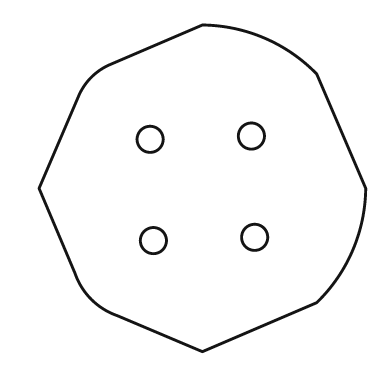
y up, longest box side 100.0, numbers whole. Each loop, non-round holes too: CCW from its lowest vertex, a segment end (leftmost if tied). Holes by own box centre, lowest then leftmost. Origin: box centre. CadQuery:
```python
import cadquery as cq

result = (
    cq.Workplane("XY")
    .moveTo(0.0, -50.0)
    .lineTo(35.0, -35.0)
    .threePointArc((46.0, -19.0), (50.0, 0.0))
    .lineTo(35.0, 35.0)
    .threePointArc((19.0, 46.0), (0.0, 50.0))
    .lineTo(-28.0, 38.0)
    .threePointArc((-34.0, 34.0), (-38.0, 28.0))
    .lineTo(-50.0, 0.0)
    .lineTo(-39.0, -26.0)
    .threePointArc((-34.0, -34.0), (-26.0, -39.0))
    .close()
    .moveTo(-15.0, -16.0)
    .circle(4.0)
    .moveTo(16.0, -15.0)
    .circle(4.0)
    .moveTo(-16.0, 15.0)
    .circle(4.0)
    .moveTo(15.0, 16.0)
    .circle(4.0)
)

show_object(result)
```